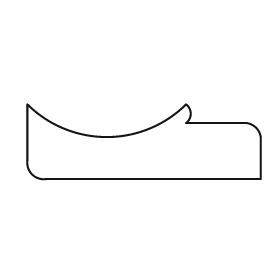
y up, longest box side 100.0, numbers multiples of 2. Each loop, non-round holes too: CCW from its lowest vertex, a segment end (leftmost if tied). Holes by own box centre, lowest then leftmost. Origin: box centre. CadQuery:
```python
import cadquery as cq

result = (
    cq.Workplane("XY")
    .moveTo(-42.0, -16.0)
    .lineTo(50.0, -16.0)
    .lineTo(50.0, 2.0)
    .threePointArc((48.0, 6.0), (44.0, 8.0))
    .lineTo(18.0, 8.0)
    .threePointArc((20.0, 12.0), (18.0, 16.0))
    .threePointArc((-16.0, 2.0), (-50.0, 16.0))
    .lineTo(-50.0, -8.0)
    .threePointArc((-48.0, -14.0), (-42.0, -16.0))
    .close()
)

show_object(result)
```